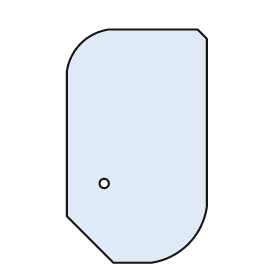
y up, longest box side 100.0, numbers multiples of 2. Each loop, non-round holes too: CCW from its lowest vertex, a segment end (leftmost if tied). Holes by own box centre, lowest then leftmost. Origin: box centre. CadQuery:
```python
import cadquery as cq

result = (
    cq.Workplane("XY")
    .moveTo(-10.0, -50.0)
    .lineTo(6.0, -50.0)
    .threePointArc((22.0, -42.0), (30.0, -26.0))
    .lineTo(30.0, 46.0)
    .lineTo(26.0, 50.0)
    .lineTo(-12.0, 50.0)
    .threePointArc((-24.0, 44.0), (-30.0, 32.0))
    .lineTo(-30.0, -30.0)
    .close()
    .moveTo(-14.0, -16.0)
    .circle(2.0)
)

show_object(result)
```